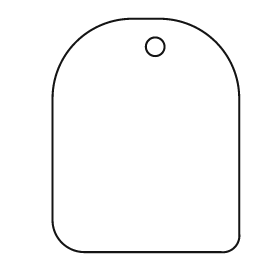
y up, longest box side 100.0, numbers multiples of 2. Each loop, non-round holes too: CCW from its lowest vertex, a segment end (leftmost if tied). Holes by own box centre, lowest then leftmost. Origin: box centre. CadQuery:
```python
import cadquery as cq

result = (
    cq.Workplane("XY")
    .moveTo(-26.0, -50.0)
    .lineTo(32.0, -50.0)
    .threePointArc((38.0, -48.0), (40.0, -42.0))
    .lineTo(40.0, 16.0)
    .threePointArc((30.0, 40.0), (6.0, 50.0))
    .lineTo(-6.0, 50.0)
    .threePointArc((-30.0, 40.0), (-40.0, 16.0))
    .lineTo(-40.0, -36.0)
    .threePointArc((-36.0, -46.0), (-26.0, -50.0))
    .close()
    .moveTo(4.0, 38.0)
    .circle(4.0)
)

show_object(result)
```